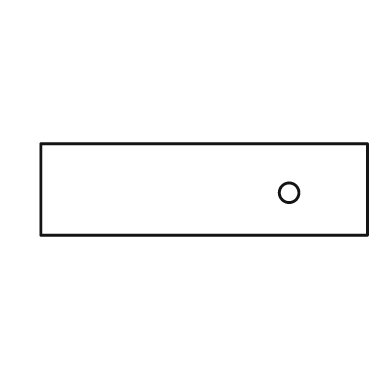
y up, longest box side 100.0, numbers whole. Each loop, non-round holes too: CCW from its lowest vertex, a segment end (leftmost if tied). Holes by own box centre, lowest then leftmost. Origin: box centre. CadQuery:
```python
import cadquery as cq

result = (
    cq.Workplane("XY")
    .moveTo(-50.0, -14.0)
    .lineTo(50.0, -14.0)
    .lineTo(50.0, 14.0)
    .lineTo(-50.0, 14.0)
    .close()
    .moveTo(26.0, -1.0)
    .circle(3.0)
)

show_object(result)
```